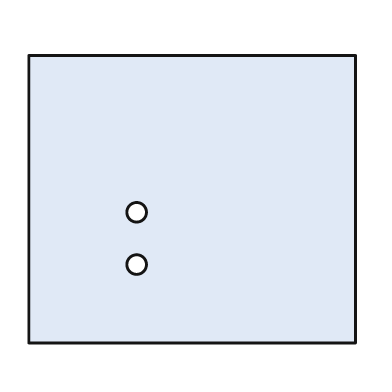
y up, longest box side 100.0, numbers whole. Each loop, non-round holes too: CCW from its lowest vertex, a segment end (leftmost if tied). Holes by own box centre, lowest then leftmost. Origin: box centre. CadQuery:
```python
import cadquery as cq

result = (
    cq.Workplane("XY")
    .moveTo(-50.0, -44.0)
    .lineTo(50.0, -44.0)
    .lineTo(50.0, 44.0)
    .lineTo(-50.0, 44.0)
    .close()
    .moveTo(-17.0, -20.0)
    .circle(3.0)
    .moveTo(-17.0, -4.0)
    .circle(3.0)
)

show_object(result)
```